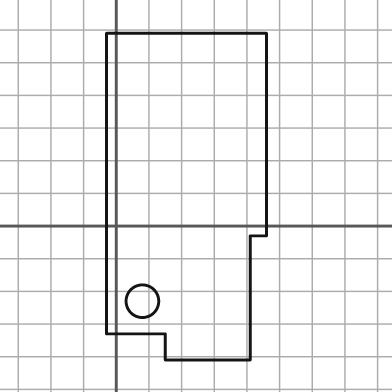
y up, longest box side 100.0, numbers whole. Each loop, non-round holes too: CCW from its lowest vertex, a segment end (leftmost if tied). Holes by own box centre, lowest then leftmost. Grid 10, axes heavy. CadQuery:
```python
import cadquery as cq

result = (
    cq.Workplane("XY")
    .moveTo(15.0, -41.0)
    .lineTo(41.0, -41.0)
    .lineTo(41.0, -3.0)
    .lineTo(46.0, -3.0)
    .lineTo(46.0, 59.0)
    .lineTo(-3.0, 59.0)
    .lineTo(-3.0, -33.0)
    .lineTo(15.0, -33.0)
    .close()
    .moveTo(8.0, -23.0)
    .circle(5.0)
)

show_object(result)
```